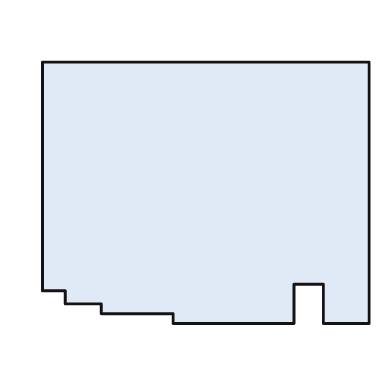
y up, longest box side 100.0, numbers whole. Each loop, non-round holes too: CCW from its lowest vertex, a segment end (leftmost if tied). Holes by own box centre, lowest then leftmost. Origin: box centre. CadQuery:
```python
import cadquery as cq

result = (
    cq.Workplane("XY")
    .moveTo(-10.0, -40.0)
    .lineTo(27.0, -40.0)
    .lineTo(27.0, -28.0)
    .lineTo(36.0, -28.0)
    .lineTo(36.0, -40.0)
    .lineTo(50.0, -40.0)
    .lineTo(50.0, 40.0)
    .lineTo(-50.0, 40.0)
    .lineTo(-50.0, -30.0)
    .lineTo(-43.0, -30.0)
    .lineTo(-43.0, -34.0)
    .lineTo(-32.0, -34.0)
    .lineTo(-32.0, -37.0)
    .lineTo(-10.0, -37.0)
    .close()
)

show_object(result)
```